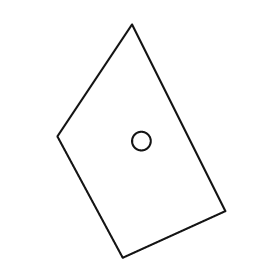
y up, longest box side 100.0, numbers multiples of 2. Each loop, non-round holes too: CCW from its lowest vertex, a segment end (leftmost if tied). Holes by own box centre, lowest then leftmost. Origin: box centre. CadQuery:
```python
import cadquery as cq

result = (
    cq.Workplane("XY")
    .moveTo(-8.0, -50.0)
    .lineTo(36.0, -30.0)
    .lineTo(-4.0, 50.0)
    .lineTo(-36.0, 2.0)
    .close()
    .moveTo(0.0, 0.0)
    .circle(4.0)
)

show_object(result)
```